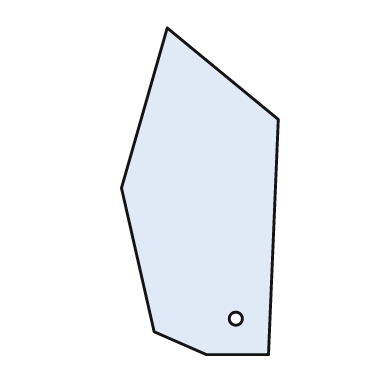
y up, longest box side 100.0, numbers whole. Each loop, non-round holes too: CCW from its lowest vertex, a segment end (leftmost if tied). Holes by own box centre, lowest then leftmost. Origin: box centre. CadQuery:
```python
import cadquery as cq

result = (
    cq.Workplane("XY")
    .moveTo(2.0, -50.0)
    .lineTo(21.0, -50.0)
    .lineTo(24.0, 22.0)
    .lineTo(-10.0, 50.0)
    .lineTo(-24.0, 1.0)
    .lineTo(-14.0, -43.0)
    .close()
    .moveTo(11.0, -39.0)
    .circle(2.0)
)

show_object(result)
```